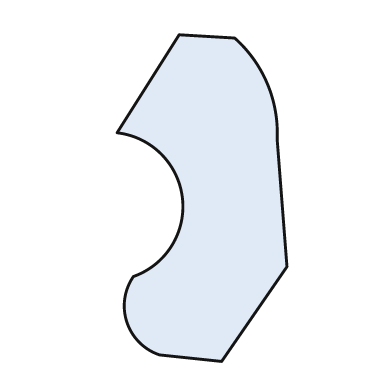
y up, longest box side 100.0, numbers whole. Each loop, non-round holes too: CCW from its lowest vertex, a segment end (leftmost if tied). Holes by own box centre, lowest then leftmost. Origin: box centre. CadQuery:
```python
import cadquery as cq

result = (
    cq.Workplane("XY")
    .moveTo(6.0, -50.0)
    .lineTo(26.0, -21.0)
    .lineTo(23.0, 18.0)
    .threePointArc((20.0, 35.0), (10.0, 49.0))
    .lineTo(-7.0, 50.0)
    .lineTo(-26.0, 20.0)
    .threePointArc((-6.0, 0.0), (-21.0, -24.0))
    .threePointArc((-23.0, -38.0), (-13.0, -48.0))
    .close()
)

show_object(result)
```